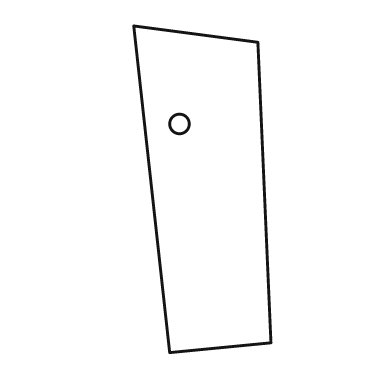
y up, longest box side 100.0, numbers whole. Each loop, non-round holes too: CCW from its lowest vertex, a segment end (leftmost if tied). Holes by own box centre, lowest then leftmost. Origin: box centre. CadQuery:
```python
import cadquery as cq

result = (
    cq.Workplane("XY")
    .moveTo(-10.0, -50.0)
    .lineTo(21.0, -47.0)
    .lineTo(17.0, 45.0)
    .lineTo(-21.0, 50.0)
    .close()
    .moveTo(-7.0, 20.0)
    .circle(3.0)
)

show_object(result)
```